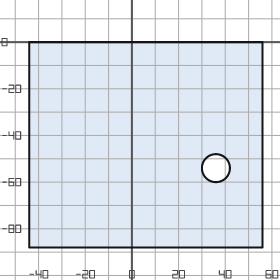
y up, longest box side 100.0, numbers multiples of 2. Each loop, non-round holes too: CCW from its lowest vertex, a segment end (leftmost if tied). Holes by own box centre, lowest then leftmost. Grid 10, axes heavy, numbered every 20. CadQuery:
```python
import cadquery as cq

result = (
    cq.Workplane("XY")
    .moveTo(-44.0, -88.0)
    .lineTo(56.0, -88.0)
    .lineTo(56.0, 0.0)
    .lineTo(-44.0, 0.0)
    .close()
    .moveTo(36.0, -54.0)
    .circle(6.0)
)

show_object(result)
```